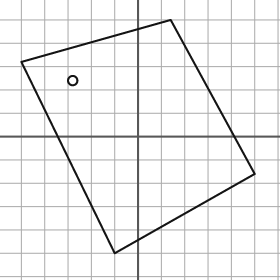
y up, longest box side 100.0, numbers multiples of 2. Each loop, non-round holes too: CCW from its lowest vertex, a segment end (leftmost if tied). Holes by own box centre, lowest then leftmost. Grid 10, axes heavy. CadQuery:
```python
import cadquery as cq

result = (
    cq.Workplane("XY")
    .moveTo(-10.0, -50.0)
    .lineTo(50.0, -16.0)
    .lineTo(14.0, 50.0)
    .lineTo(-50.0, 32.0)
    .close()
    .moveTo(-28.0, 24.0)
    .circle(2.0)
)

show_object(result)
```